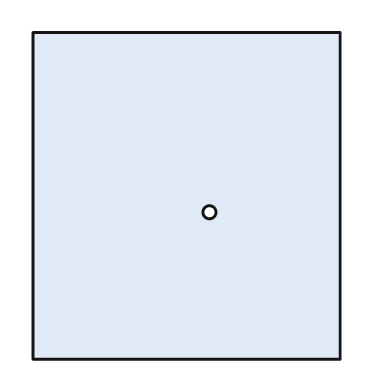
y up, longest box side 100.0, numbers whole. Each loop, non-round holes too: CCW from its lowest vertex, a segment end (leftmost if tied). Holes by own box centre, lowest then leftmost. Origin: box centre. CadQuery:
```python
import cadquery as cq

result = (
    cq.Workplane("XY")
    .moveTo(-47.0, -50.0)
    .lineTo(47.0, -50.0)
    .lineTo(47.0, 50.0)
    .lineTo(-47.0, 50.0)
    .close()
    .moveTo(7.0, -5.0)
    .circle(2.0)
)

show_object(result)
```